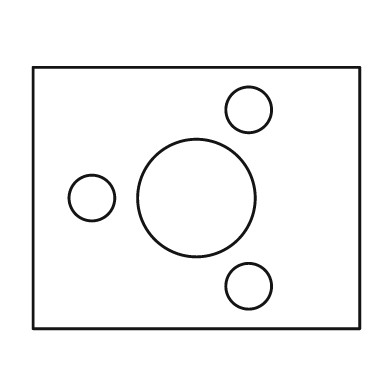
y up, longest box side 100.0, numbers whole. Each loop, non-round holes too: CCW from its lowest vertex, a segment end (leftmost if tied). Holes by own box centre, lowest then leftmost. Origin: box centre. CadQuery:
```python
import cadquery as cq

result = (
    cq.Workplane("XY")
    .moveTo(-50.0, -40.0)
    .lineTo(50.0, -40.0)
    .lineTo(50.0, 40.0)
    .lineTo(-50.0, 40.0)
    .close()
    .moveTo(16.0, -27.0)
    .circle(7.0)
    .moveTo(-32.0, 0.0)
    .circle(7.0)
    .moveTo(0.0, 0.0)
    .circle(18.0)
    .moveTo(16.0, 27.0)
    .circle(7.0)
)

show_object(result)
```